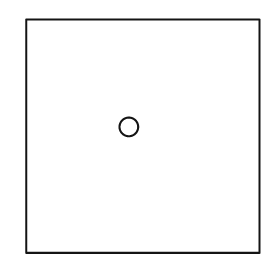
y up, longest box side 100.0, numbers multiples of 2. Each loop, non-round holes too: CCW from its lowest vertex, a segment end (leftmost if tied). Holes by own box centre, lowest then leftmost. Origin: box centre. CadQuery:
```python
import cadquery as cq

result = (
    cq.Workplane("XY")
    .moveTo(-50.0, -50.0)
    .lineTo(50.0, -50.0)
    .lineTo(50.0, 50.0)
    .lineTo(-50.0, 50.0)
    .close()
    .moveTo(-6.0, 4.0)
    .circle(4.0)
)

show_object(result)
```